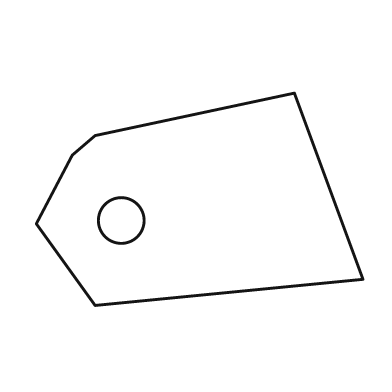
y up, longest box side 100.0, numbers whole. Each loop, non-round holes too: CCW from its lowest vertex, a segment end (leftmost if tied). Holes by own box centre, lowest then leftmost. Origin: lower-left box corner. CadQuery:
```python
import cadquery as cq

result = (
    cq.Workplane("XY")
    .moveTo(18.0, 0.0)
    .lineTo(100.0, 8.0)
    .lineTo(79.0, 65.0)
    .lineTo(18.0, 52.0)
    .lineTo(11.0, 46.0)
    .lineTo(0.0, 25.0)
    .close()
    .moveTo(26.0, 26.0)
    .circle(7.0)
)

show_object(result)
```